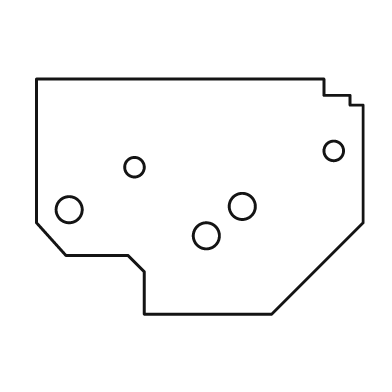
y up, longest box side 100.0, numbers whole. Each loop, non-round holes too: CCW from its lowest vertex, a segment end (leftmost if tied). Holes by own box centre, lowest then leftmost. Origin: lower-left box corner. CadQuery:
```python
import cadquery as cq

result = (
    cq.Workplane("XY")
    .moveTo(33.0, 0.0)
    .lineTo(72.0, 0.0)
    .lineTo(100.0, 28.0)
    .lineTo(100.0, 64.0)
    .lineTo(96.0, 64.0)
    .lineTo(96.0, 67.0)
    .lineTo(88.0, 67.0)
    .lineTo(88.0, 72.0)
    .lineTo(0.0, 72.0)
    .lineTo(0.0, 28.0)
    .lineTo(9.0, 18.0)
    .lineTo(28.0, 18.0)
    .lineTo(33.0, 13.0)
    .close()
    .moveTo(52.0, 24.0)
    .circle(4.0)
    .moveTo(10.0, 32.0)
    .circle(4.0)
    .moveTo(63.0, 33.0)
    .circle(4.0)
    .moveTo(30.0, 45.0)
    .circle(3.0)
    .moveTo(91.0, 50.0)
    .circle(3.0)
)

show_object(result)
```